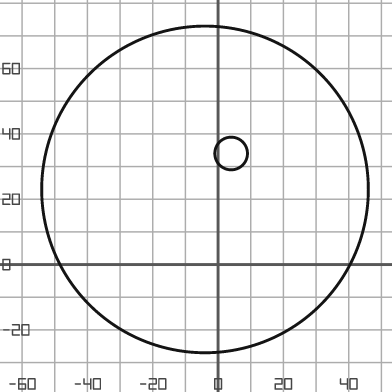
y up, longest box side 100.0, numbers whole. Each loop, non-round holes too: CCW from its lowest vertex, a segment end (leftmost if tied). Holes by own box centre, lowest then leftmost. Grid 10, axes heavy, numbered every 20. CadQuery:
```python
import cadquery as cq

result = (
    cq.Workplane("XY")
    .moveTo(-4.0, 23.0)
    .circle(50.0)
    .moveTo(4.0, 34.0)
    .circle(5.0)
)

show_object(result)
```